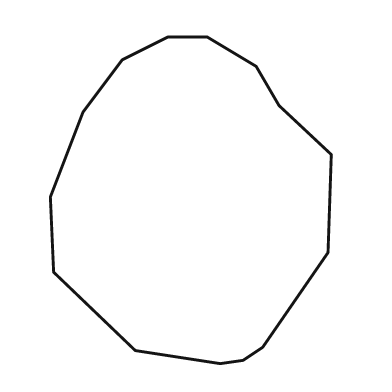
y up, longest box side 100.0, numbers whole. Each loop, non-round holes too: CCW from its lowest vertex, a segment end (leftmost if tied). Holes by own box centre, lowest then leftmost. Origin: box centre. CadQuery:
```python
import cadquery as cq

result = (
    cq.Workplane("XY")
    .moveTo(9.0, -50.0)
    .lineTo(16.0, -49.0)
    .lineTo(22.0, -45.0)
    .lineTo(42.0, -16.0)
    .lineTo(43.0, 14.0)
    .lineTo(27.0, 29.0)
    .lineTo(20.0, 41.0)
    .lineTo(5.0, 50.0)
    .lineTo(-7.0, 50.0)
    .lineTo(-21.0, 43.0)
    .lineTo(-33.0, 27.0)
    .lineTo(-43.0, 1.0)
    .lineTo(-42.0, -22.0)
    .lineTo(-17.0, -46.0)
    .close()
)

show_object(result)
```